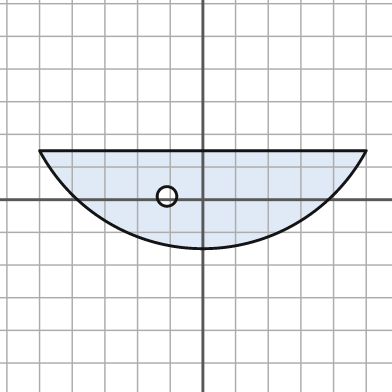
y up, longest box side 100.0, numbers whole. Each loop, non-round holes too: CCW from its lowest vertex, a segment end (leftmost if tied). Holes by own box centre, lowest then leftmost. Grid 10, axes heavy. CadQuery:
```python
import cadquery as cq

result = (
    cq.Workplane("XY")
    .moveTo(-50.0, 15.0)
    .threePointArc((0.0, -15.0), (50.0, 15.0))
    .close()
    .moveTo(-11.0, 1.0)
    .circle(3.0)
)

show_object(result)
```